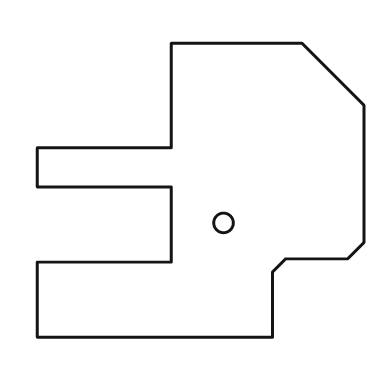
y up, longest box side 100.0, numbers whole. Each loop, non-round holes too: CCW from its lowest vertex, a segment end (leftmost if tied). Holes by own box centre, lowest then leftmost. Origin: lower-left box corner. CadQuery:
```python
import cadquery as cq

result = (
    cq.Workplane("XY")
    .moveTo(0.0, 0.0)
    .lineTo(72.0, 0.0)
    .lineTo(72.0, 20.0)
    .lineTo(76.0, 24.0)
    .lineTo(95.0, 24.0)
    .lineTo(100.0, 29.0)
    .lineTo(100.0, 71.0)
    .lineTo(81.0, 90.0)
    .lineTo(41.0, 90.0)
    .lineTo(41.0, 58.0)
    .lineTo(0.0, 58.0)
    .lineTo(0.0, 46.0)
    .lineTo(41.0, 46.0)
    .lineTo(41.0, 23.0)
    .lineTo(0.0, 23.0)
    .close()
    .moveTo(57.0, 35.0)
    .circle(3.0)
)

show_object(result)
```